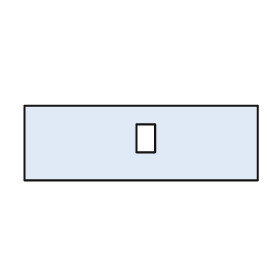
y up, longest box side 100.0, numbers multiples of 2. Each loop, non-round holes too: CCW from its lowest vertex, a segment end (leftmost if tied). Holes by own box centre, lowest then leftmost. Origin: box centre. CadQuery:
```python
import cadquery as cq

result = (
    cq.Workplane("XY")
    .moveTo(-50.0, -16.0)
    .lineTo(50.0, -16.0)
    .lineTo(50.0, 16.0)
    .lineTo(-50.0, 16.0)
    .close()
    .moveTo(-2.0, -4.0)
    .lineTo(6.0, -4.0)
    .lineTo(6.0, 8.0)
    .lineTo(-2.0, 8.0)
    .close()
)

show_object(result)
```